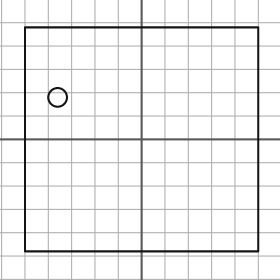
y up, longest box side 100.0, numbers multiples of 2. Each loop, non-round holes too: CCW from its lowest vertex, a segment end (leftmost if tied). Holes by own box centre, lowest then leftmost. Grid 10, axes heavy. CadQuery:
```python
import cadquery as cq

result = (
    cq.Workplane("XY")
    .moveTo(-50.0, -48.0)
    .lineTo(50.0, -48.0)
    .lineTo(50.0, 48.0)
    .lineTo(-50.0, 48.0)
    .close()
    .moveTo(-36.0, 18.0)
    .circle(4.0)
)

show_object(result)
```